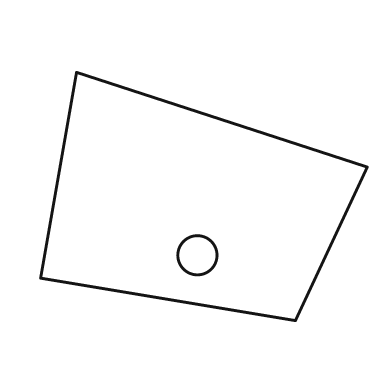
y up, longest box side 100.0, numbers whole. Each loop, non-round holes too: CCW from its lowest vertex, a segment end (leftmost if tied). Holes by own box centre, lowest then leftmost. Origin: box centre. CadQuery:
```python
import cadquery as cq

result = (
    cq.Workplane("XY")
    .moveTo(28.0, -38.0)
    .lineTo(50.0, 9.0)
    .lineTo(-39.0, 38.0)
    .lineTo(-50.0, -25.0)
    .close()
    .moveTo(-2.0, -18.0)
    .circle(6.0)
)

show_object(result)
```